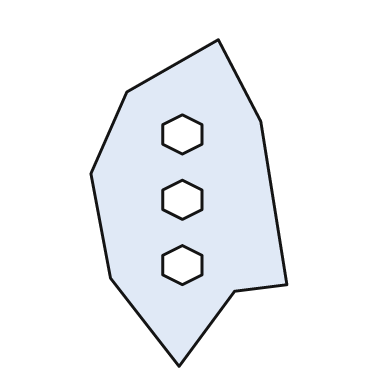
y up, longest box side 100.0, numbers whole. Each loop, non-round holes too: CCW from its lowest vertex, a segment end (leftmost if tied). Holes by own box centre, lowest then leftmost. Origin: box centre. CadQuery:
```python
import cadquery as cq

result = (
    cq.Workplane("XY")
    .moveTo(-3.0, -50.0)
    .lineTo(14.0, -27.0)
    .lineTo(30.0, -25.0)
    .lineTo(22.0, 25.0)
    .lineTo(9.0, 50.0)
    .lineTo(-19.0, 34.0)
    .lineTo(-30.0, 9.0)
    .lineTo(-24.0, -23.0)
    .close()
    .moveTo(-2.0, -25.0)
    .lineTo(4.0, -22.0)
    .lineTo(4.0, -16.0)
    .lineTo(-2.0, -13.0)
    .lineTo(-8.0, -16.0)
    .lineTo(-8.0, -22.0)
    .close()
    .moveTo(-2.0, -5.0)
    .lineTo(4.0, -2.0)
    .lineTo(4.0, 4.0)
    .lineTo(-2.0, 7.0)
    .lineTo(-8.0, 4.0)
    .lineTo(-8.0, -2.0)
    .close()
    .moveTo(-2.0, 15.0)
    .lineTo(4.0, 18.0)
    .lineTo(4.0, 24.0)
    .lineTo(-2.0, 27.0)
    .lineTo(-8.0, 24.0)
    .lineTo(-8.0, 18.0)
    .close()
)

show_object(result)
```